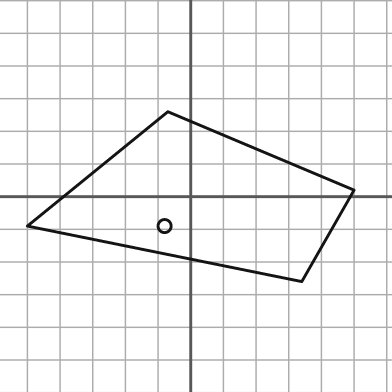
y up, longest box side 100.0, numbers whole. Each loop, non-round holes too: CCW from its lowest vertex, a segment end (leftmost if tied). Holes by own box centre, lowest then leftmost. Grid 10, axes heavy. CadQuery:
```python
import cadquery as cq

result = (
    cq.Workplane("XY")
    .moveTo(34.0, -26.0)
    .lineTo(50.0, 2.0)
    .lineTo(-7.0, 26.0)
    .lineTo(-50.0, -9.0)
    .close()
    .moveTo(-8.0, -9.0)
    .circle(2.0)
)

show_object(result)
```